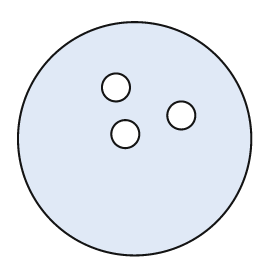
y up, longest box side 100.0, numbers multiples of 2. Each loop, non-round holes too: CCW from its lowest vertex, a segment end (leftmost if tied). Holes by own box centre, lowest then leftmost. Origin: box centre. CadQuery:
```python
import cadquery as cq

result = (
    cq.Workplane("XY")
    .moveTo(0.0, 0.0)
    .circle(50.0)
    .moveTo(-4.0, 2.0)
    .circle(6.0)
    .moveTo(20.0, 10.0)
    .circle(6.0)
    .moveTo(-8.0, 22.0)
    .circle(6.0)
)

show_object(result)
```